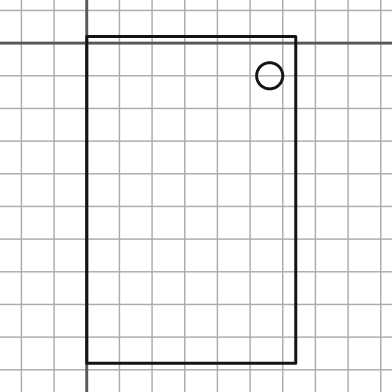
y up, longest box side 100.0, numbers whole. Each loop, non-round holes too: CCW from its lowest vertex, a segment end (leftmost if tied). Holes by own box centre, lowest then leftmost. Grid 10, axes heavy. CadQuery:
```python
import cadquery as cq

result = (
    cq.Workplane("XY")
    .moveTo(0.0, -98.0)
    .lineTo(64.0, -98.0)
    .lineTo(64.0, 2.0)
    .lineTo(0.0, 2.0)
    .close()
    .moveTo(56.0, -10.0)
    .circle(4.0)
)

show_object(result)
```